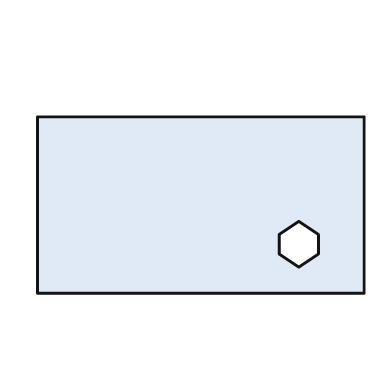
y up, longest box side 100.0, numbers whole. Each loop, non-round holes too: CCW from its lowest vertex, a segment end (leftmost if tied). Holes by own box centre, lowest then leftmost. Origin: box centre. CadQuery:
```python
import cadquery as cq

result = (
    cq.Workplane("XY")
    .moveTo(-50.0, -27.0)
    .lineTo(50.0, -27.0)
    .lineTo(50.0, 27.0)
    .lineTo(-50.0, 27.0)
    .close()
    .moveTo(30.0, -19.0)
    .lineTo(36.0, -15.0)
    .lineTo(36.0, -9.0)
    .lineTo(30.0, -5.0)
    .lineTo(24.0, -9.0)
    .lineTo(24.0, -15.0)
    .close()
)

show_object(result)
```